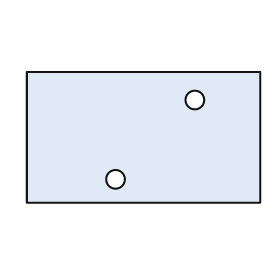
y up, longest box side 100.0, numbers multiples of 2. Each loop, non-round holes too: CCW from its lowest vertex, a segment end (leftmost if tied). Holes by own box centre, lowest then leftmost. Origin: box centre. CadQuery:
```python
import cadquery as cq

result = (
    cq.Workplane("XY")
    .moveTo(-50.0, -28.0)
    .lineTo(50.0, -28.0)
    .lineTo(50.0, 28.0)
    .lineTo(-50.0, 28.0)
    .close()
    .moveTo(-12.0, -18.0)
    .circle(4.0)
    .moveTo(22.0, 16.0)
    .circle(4.0)
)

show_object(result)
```